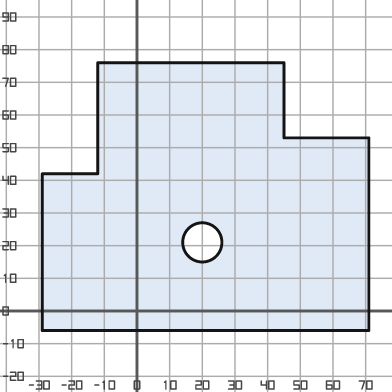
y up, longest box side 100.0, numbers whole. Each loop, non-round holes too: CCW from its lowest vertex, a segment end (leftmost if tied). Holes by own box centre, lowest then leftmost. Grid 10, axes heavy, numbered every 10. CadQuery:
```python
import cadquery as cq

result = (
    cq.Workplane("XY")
    .moveTo(-29.0, -6.0)
    .lineTo(71.0, -6.0)
    .lineTo(71.0, 53.0)
    .lineTo(45.0, 53.0)
    .lineTo(45.0, 76.0)
    .lineTo(-12.0, 76.0)
    .lineTo(-12.0, 42.0)
    .lineTo(-29.0, 42.0)
    .close()
    .moveTo(20.0, 21.0)
    .circle(6.0)
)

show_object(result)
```